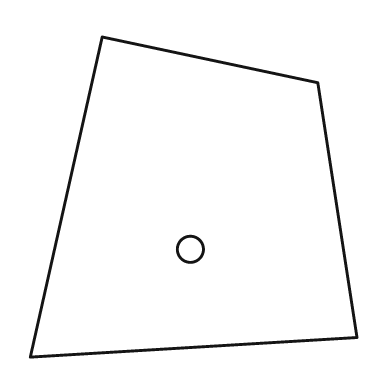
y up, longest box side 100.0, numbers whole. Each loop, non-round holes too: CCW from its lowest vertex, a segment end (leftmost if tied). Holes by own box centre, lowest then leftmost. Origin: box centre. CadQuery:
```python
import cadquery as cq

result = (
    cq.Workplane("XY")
    .moveTo(-50.0, -49.0)
    .lineTo(50.0, -43.0)
    .lineTo(38.0, 35.0)
    .lineTo(-28.0, 49.0)
    .close()
    .moveTo(-1.0, -16.0)
    .circle(4.0)
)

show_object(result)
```